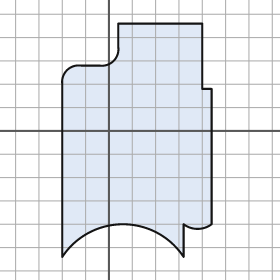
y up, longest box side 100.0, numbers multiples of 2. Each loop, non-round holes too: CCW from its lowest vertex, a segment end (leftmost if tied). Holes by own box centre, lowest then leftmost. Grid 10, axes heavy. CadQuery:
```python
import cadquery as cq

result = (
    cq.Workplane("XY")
    .moveTo(-20.0, -54.0)
    .threePointArc((6.0, -40.0), (32.0, -54.0))
    .lineTo(32.0, -40.0)
    .threePointArc((38.0, -42.0), (44.0, -40.0))
    .lineTo(44.0, 18.0)
    .lineTo(40.0, 18.0)
    .lineTo(40.0, 46.0)
    .lineTo(4.0, 46.0)
    .lineTo(4.0, 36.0)
    .threePointArc((2.0, 30.0), (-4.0, 28.0))
    .lineTo(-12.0, 28.0)
    .threePointArc((-18.0, 26.0), (-20.0, 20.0))
    .close()
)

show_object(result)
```